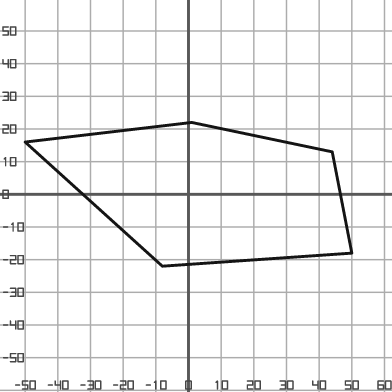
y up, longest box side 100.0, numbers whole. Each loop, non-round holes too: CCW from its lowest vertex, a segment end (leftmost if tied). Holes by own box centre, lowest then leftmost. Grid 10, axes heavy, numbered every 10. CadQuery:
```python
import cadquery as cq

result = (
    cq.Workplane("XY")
    .moveTo(-8.0, -22.0)
    .lineTo(50.0, -18.0)
    .lineTo(44.0, 13.0)
    .lineTo(1.0, 22.0)
    .lineTo(-50.0, 16.0)
    .close()
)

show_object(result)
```